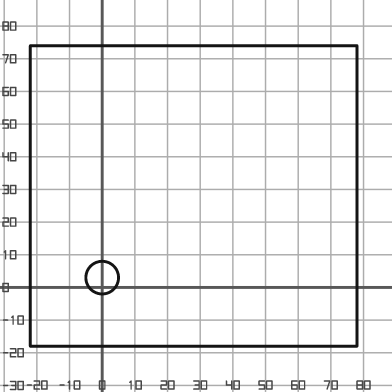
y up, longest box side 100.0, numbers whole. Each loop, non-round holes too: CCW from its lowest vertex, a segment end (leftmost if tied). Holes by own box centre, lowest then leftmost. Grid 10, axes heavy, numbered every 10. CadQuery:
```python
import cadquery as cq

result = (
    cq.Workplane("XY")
    .moveTo(-22.0, -18.0)
    .lineTo(78.0, -18.0)
    .lineTo(78.0, 74.0)
    .lineTo(-22.0, 74.0)
    .close()
    .moveTo(0.0, 3.0)
    .circle(5.0)
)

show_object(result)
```